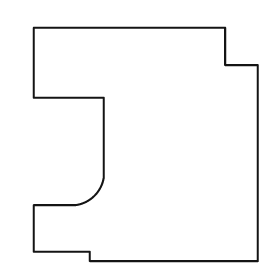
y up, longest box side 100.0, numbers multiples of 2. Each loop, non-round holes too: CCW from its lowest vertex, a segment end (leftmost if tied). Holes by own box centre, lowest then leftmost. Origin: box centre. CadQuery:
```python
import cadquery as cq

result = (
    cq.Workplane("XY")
    .moveTo(-24.0, -50.0)
    .lineTo(48.0, -50.0)
    .lineTo(48.0, 34.0)
    .lineTo(34.0, 34.0)
    .lineTo(34.0, 50.0)
    .lineTo(-48.0, 50.0)
    .lineTo(-48.0, 20.0)
    .lineTo(-18.0, 20.0)
    .lineTo(-18.0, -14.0)
    .threePointArc((-22.0, -22.0), (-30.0, -26.0))
    .lineTo(-48.0, -26.0)
    .lineTo(-48.0, -46.0)
    .lineTo(-24.0, -46.0)
    .close()
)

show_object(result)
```